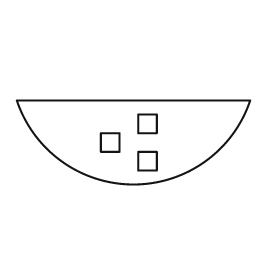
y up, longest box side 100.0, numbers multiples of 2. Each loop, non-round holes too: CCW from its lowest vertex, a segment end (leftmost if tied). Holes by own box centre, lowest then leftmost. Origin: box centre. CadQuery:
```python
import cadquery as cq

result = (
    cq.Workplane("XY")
    .moveTo(-50.0, 18.0)
    .threePointArc((0.0, -18.0), (50.0, 18.0))
    .close()
    .moveTo(2.0, -12.0)
    .lineTo(10.0, -12.0)
    .lineTo(10.0, -4.0)
    .lineTo(2.0, -4.0)
    .close()
    .moveTo(-14.0, -4.0)
    .lineTo(-6.0, -4.0)
    .lineTo(-6.0, 4.0)
    .lineTo(-14.0, 4.0)
    .close()
    .moveTo(2.0, 4.0)
    .lineTo(10.0, 4.0)
    .lineTo(10.0, 12.0)
    .lineTo(2.0, 12.0)
    .close()
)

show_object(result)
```